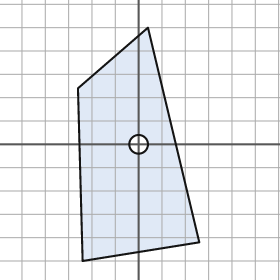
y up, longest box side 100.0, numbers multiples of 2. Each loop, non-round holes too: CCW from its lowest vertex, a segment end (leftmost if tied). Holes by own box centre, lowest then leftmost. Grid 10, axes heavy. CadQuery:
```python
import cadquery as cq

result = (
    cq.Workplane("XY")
    .moveTo(-24.0, -50.0)
    .lineTo(26.0, -42.0)
    .lineTo(4.0, 50.0)
    .lineTo(-26.0, 24.0)
    .close()
    .moveTo(0.0, 0.0)
    .circle(4.0)
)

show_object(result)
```